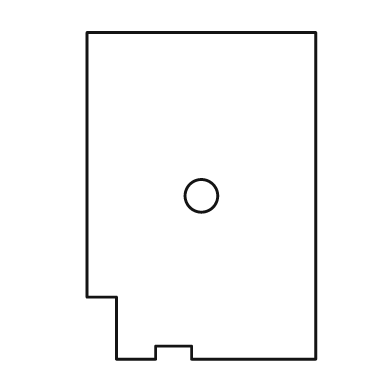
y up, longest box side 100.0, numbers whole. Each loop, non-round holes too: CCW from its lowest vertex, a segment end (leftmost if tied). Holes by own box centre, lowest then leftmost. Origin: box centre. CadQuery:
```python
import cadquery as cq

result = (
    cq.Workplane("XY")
    .moveTo(-26.0, -50.0)
    .lineTo(-14.0, -50.0)
    .lineTo(-14.0, -46.0)
    .lineTo(-3.0, -46.0)
    .lineTo(-3.0, -50.0)
    .lineTo(35.0, -50.0)
    .lineTo(35.0, 50.0)
    .lineTo(-35.0, 50.0)
    .lineTo(-35.0, -31.0)
    .lineTo(-26.0, -31.0)
    .close()
    .moveTo(0.0, 0.0)
    .circle(5.0)
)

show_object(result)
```